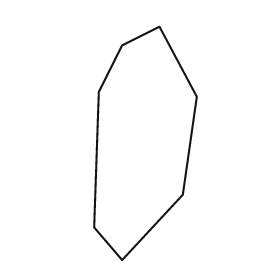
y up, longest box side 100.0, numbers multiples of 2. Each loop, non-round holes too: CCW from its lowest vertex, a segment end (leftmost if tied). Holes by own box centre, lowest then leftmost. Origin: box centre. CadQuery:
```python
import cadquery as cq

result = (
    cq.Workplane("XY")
    .moveTo(-10.0, -50.0)
    .lineTo(16.0, -22.0)
    .lineTo(22.0, 20.0)
    .lineTo(6.0, 50.0)
    .lineTo(-10.0, 42.0)
    .lineTo(-20.0, 22.0)
    .lineTo(-22.0, -36.0)
    .close()
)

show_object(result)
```